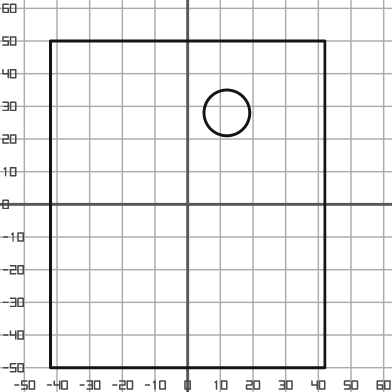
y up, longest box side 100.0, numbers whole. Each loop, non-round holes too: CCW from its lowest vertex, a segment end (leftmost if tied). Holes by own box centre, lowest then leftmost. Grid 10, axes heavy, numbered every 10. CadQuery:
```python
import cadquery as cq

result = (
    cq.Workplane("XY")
    .moveTo(-42.0, -50.0)
    .lineTo(42.0, -50.0)
    .lineTo(42.0, 50.0)
    .lineTo(-42.0, 50.0)
    .close()
    .moveTo(12.0, 28.0)
    .circle(7.0)
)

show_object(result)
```